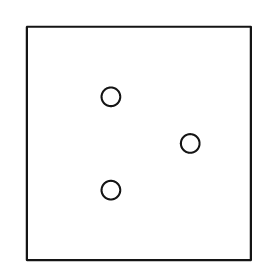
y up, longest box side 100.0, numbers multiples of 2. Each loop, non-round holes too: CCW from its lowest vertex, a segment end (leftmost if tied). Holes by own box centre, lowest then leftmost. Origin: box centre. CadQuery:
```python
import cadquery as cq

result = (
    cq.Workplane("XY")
    .moveTo(-48.0, -50.0)
    .lineTo(48.0, -50.0)
    .lineTo(48.0, 50.0)
    .lineTo(-48.0, 50.0)
    .close()
    .moveTo(-12.0, -20.0)
    .circle(4.0)
    .moveTo(22.0, 0.0)
    .circle(4.0)
    .moveTo(-12.0, 20.0)
    .circle(4.0)
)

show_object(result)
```